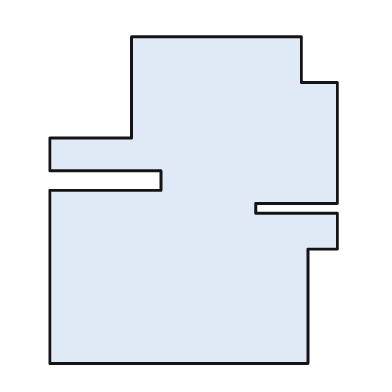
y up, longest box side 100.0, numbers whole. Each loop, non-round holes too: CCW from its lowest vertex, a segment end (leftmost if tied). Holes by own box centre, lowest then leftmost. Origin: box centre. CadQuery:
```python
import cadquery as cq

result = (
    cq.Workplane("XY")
    .moveTo(-44.0, -50.0)
    .lineTo(35.0, -50.0)
    .lineTo(35.0, -15.0)
    .lineTo(44.0, -15.0)
    .lineTo(44.0, -4.0)
    .lineTo(19.0, -4.0)
    .lineTo(19.0, -1.0)
    .lineTo(44.0, -1.0)
    .lineTo(44.0, 36.0)
    .lineTo(33.0, 36.0)
    .lineTo(33.0, 50.0)
    .lineTo(-19.0, 50.0)
    .lineTo(-19.0, 19.0)
    .lineTo(-44.0, 19.0)
    .lineTo(-44.0, 9.0)
    .lineTo(-10.0, 9.0)
    .lineTo(-10.0, 3.0)
    .lineTo(-44.0, 3.0)
    .close()
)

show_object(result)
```